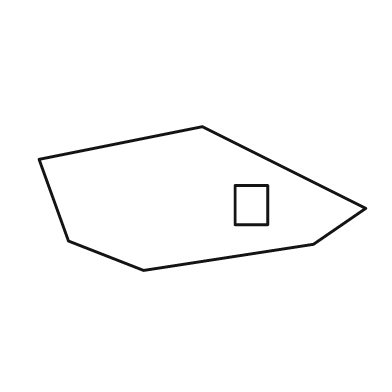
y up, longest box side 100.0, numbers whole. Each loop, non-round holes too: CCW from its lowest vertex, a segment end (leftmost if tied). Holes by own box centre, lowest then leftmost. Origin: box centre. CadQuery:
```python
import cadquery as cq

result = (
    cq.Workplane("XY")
    .moveTo(-18.0, -22.0)
    .lineTo(34.0, -14.0)
    .lineTo(50.0, -3.0)
    .lineTo(0.0, 22.0)
    .lineTo(-50.0, 12.0)
    .lineTo(-41.0, -13.0)
    .close()
    .moveTo(10.0, -8.0)
    .lineTo(20.0, -8.0)
    .lineTo(20.0, 4.0)
    .lineTo(10.0, 4.0)
    .close()
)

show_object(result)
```